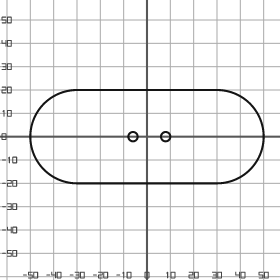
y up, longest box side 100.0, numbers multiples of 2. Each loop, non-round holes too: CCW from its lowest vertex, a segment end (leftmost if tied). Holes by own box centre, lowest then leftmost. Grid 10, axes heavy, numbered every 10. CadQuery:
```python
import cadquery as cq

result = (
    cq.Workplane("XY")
    .moveTo(-30.0, -20.0)
    .lineTo(30.0, -20.0)
    .threePointArc((50.0, 0.0), (30.0, 20.0))
    .lineTo(-30.0, 20.0)
    .threePointArc((-50.0, 0.0), (-30.0, -20.0))
    .close()
    .moveTo(-6.0, 0.0)
    .circle(2.0)
    .moveTo(8.0, 0.0)
    .circle(2.0)
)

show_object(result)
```